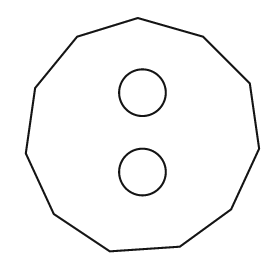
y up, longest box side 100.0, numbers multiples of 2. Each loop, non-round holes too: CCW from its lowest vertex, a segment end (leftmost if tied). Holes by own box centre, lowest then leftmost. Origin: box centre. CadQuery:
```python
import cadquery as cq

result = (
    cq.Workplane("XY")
    .moveTo(-14.0, -50.0)
    .lineTo(16.0, -48.0)
    .lineTo(38.0, -32.0)
    .lineTo(50.0, -6.0)
    .lineTo(46.0, 22.0)
    .lineTo(26.0, 42.0)
    .lineTo(-2.0, 50.0)
    .lineTo(-28.0, 42.0)
    .lineTo(-46.0, 20.0)
    .lineTo(-50.0, -8.0)
    .lineTo(-38.0, -34.0)
    .close()
    .moveTo(0.0, -16.0)
    .circle(10.0)
    .moveTo(0.0, 18.0)
    .circle(10.0)
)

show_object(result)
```